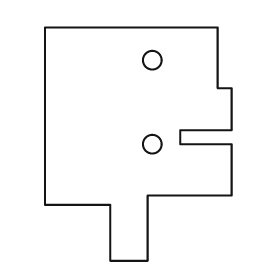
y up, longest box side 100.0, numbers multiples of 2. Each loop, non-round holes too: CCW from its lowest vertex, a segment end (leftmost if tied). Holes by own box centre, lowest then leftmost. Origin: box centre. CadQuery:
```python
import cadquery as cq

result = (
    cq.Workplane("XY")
    .moveTo(-12.0, -50.0)
    .lineTo(4.0, -50.0)
    .lineTo(4.0, -22.0)
    .lineTo(40.0, -22.0)
    .lineTo(40.0, 0.0)
    .lineTo(18.0, 0.0)
    .lineTo(18.0, 6.0)
    .lineTo(40.0, 6.0)
    .lineTo(40.0, 24.0)
    .lineTo(34.0, 24.0)
    .lineTo(34.0, 50.0)
    .lineTo(-40.0, 50.0)
    .lineTo(-40.0, -26.0)
    .lineTo(-12.0, -26.0)
    .close()
    .moveTo(6.0, 0.0)
    .circle(4.0)
    .moveTo(6.0, 36.0)
    .circle(4.0)
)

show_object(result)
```